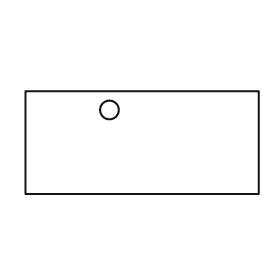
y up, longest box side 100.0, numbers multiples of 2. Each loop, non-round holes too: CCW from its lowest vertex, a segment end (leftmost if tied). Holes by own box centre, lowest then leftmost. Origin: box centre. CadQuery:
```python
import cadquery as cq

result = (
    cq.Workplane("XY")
    .moveTo(-50.0, -22.0)
    .lineTo(50.0, -22.0)
    .lineTo(50.0, 22.0)
    .lineTo(-50.0, 22.0)
    .close()
    .moveTo(-14.0, 14.0)
    .circle(4.0)
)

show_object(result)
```